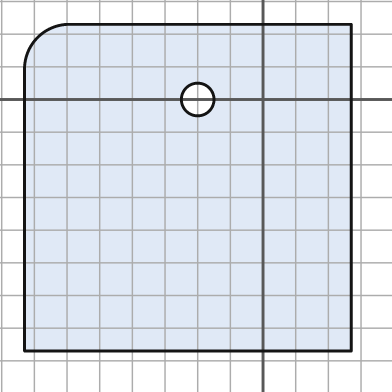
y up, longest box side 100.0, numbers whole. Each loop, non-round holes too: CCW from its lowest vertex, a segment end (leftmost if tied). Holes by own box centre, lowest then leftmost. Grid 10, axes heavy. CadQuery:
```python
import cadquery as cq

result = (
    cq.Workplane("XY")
    .moveTo(-73.0, -77.0)
    .lineTo(27.0, -77.0)
    .lineTo(27.0, 23.0)
    .lineTo(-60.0, 23.0)
    .threePointArc((-69.0, 19.0), (-73.0, 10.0))
    .close()
    .moveTo(-20.0, 0.0)
    .circle(5.0)
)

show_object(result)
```